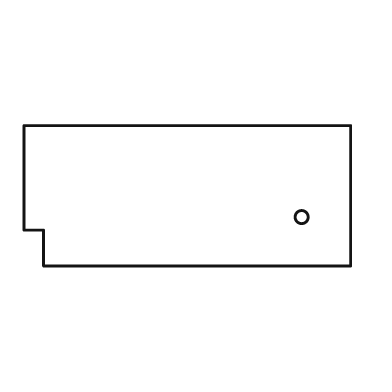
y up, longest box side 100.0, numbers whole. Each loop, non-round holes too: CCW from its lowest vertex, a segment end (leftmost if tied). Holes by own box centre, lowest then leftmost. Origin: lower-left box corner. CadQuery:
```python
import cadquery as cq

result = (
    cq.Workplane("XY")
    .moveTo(6.0, 0.0)
    .lineTo(100.0, 0.0)
    .lineTo(100.0, 43.0)
    .lineTo(0.0, 43.0)
    .lineTo(0.0, 11.0)
    .lineTo(6.0, 11.0)
    .close()
    .moveTo(85.0, 15.0)
    .circle(2.0)
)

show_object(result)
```